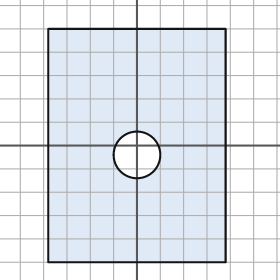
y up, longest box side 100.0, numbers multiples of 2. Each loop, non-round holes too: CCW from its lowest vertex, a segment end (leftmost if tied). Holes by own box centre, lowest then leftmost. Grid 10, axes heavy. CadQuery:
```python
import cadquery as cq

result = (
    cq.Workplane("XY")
    .moveTo(-38.0, -50.0)
    .lineTo(38.0, -50.0)
    .lineTo(38.0, 50.0)
    .lineTo(-38.0, 50.0)
    .close()
    .moveTo(0.0, -4.0)
    .circle(10.0)
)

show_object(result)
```